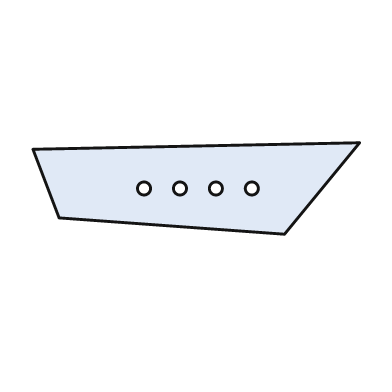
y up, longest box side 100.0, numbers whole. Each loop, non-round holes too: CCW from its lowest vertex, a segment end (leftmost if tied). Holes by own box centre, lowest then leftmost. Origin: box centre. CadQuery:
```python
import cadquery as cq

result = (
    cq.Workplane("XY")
    .moveTo(27.0, -14.0)
    .lineTo(50.0, 14.0)
    .lineTo(-50.0, 12.0)
    .lineTo(-42.0, -9.0)
    .close()
    .moveTo(-16.0, 0.0)
    .circle(2.0)
    .moveTo(-5.0, 0.0)
    .circle(2.0)
    .moveTo(6.0, 0.0)
    .circle(2.0)
    .moveTo(17.0, 0.0)
    .circle(2.0)
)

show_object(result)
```